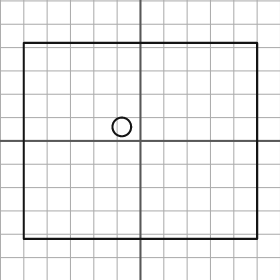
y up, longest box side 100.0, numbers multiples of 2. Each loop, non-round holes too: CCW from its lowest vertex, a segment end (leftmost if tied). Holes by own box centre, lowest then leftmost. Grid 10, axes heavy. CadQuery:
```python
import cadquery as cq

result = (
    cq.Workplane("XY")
    .moveTo(-50.0, -42.0)
    .lineTo(50.0, -42.0)
    .lineTo(50.0, 42.0)
    .lineTo(-50.0, 42.0)
    .close()
    .moveTo(-8.0, 6.0)
    .circle(4.0)
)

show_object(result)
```